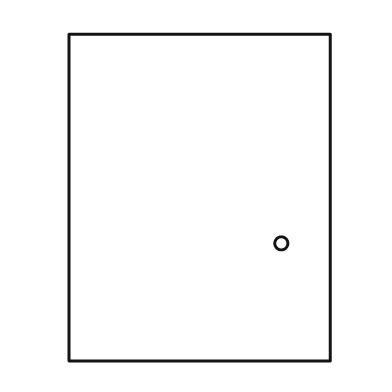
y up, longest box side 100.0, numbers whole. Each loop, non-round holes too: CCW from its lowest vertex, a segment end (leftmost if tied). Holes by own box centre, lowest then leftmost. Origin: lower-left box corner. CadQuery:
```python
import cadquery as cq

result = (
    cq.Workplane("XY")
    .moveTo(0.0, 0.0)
    .lineTo(80.0, 0.0)
    .lineTo(80.0, 100.0)
    .lineTo(0.0, 100.0)
    .close()
    .moveTo(65.0, 36.0)
    .circle(2.0)
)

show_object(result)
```